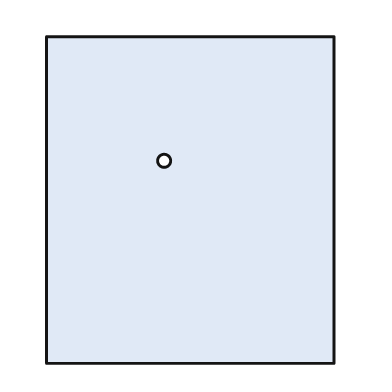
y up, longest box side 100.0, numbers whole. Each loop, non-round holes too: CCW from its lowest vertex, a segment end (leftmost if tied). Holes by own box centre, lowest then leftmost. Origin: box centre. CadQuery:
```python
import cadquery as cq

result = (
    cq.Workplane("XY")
    .moveTo(-44.0, -50.0)
    .lineTo(44.0, -50.0)
    .lineTo(44.0, 50.0)
    .lineTo(-44.0, 50.0)
    .close()
    .moveTo(-8.0, 12.0)
    .circle(2.0)
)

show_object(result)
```